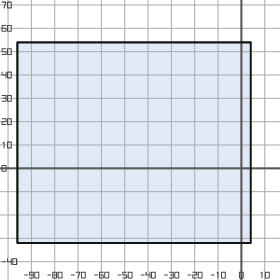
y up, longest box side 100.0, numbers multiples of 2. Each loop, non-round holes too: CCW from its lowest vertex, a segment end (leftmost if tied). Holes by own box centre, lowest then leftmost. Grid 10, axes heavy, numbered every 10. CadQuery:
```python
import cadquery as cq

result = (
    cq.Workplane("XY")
    .moveTo(-96.0, -32.0)
    .lineTo(4.0, -32.0)
    .lineTo(4.0, 54.0)
    .lineTo(-96.0, 54.0)
    .close()
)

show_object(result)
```